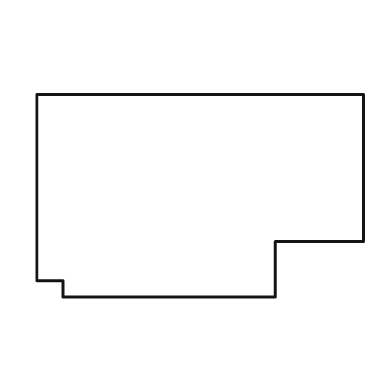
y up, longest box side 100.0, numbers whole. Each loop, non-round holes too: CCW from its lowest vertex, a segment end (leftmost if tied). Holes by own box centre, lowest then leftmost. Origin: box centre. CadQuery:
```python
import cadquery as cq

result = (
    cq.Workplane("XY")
    .moveTo(-42.0, -31.0)
    .lineTo(23.0, -31.0)
    .lineTo(23.0, -14.0)
    .lineTo(50.0, -14.0)
    .lineTo(50.0, 31.0)
    .lineTo(-50.0, 31.0)
    .lineTo(-50.0, -26.0)
    .lineTo(-42.0, -26.0)
    .close()
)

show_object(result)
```